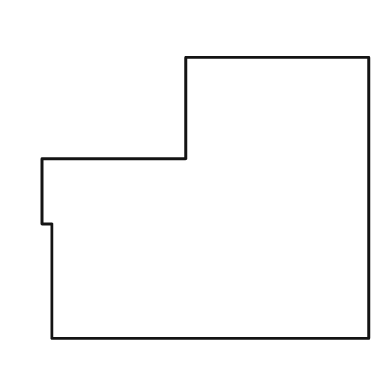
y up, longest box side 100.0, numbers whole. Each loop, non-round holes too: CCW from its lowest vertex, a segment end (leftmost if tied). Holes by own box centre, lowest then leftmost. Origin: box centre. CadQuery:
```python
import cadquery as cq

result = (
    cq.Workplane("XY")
    .moveTo(-47.0, -43.0)
    .lineTo(50.0, -43.0)
    .lineTo(50.0, 43.0)
    .lineTo(-6.0, 43.0)
    .lineTo(-6.0, 12.0)
    .lineTo(-50.0, 12.0)
    .lineTo(-50.0, -8.0)
    .lineTo(-47.0, -8.0)
    .close()
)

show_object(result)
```